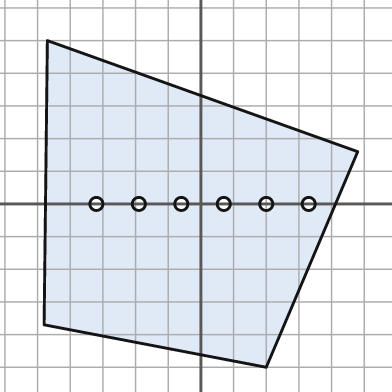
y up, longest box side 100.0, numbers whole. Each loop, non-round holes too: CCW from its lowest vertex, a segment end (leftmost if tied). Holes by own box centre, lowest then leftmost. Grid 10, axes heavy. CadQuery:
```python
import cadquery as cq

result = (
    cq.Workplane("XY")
    .moveTo(20.0, -50.0)
    .lineTo(48.0, 16.0)
    .lineTo(-47.0, 50.0)
    .lineTo(-48.0, -37.0)
    .close()
    .moveTo(-32.0, 0.0)
    .circle(2.0)
    .moveTo(-19.0, 0.0)
    .circle(2.0)
    .moveTo(-6.0, 0.0)
    .circle(2.0)
    .moveTo(7.0, 0.0)
    .circle(2.0)
    .moveTo(20.0, 0.0)
    .circle(2.0)
    .moveTo(33.0, 0.0)
    .circle(2.0)
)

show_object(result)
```